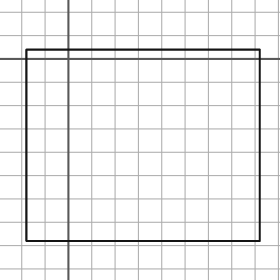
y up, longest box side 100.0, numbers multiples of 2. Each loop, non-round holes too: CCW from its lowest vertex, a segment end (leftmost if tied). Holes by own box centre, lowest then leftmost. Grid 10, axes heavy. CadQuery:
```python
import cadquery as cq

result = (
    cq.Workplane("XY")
    .moveTo(-18.0, -78.0)
    .lineTo(82.0, -78.0)
    .lineTo(82.0, 4.0)
    .lineTo(-18.0, 4.0)
    .close()
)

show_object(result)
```